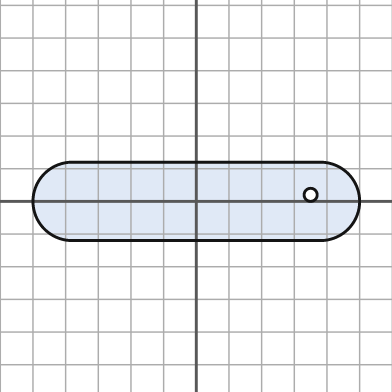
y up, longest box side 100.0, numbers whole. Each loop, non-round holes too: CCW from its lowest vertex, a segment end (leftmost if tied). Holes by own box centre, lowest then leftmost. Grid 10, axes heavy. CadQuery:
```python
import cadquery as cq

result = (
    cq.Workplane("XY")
    .moveTo(-38.0, -12.0)
    .lineTo(38.0, -12.0)
    .threePointArc((50.0, 0.0), (38.0, 12.0))
    .lineTo(-38.0, 12.0)
    .threePointArc((-50.0, 0.0), (-38.0, -12.0))
    .close()
    .moveTo(35.0, 2.0)
    .circle(2.0)
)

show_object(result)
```